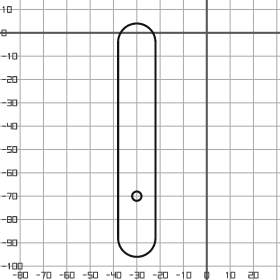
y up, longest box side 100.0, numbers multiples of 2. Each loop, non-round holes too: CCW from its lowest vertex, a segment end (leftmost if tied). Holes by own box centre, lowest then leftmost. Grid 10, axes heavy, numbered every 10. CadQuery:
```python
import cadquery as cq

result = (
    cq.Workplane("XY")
    .moveTo(-38.0, -88.0)
    .threePointArc((-30.0, -96.0), (-22.0, -88.0))
    .lineTo(-22.0, -4.0)
    .threePointArc((-30.0, 4.0), (-38.0, -4.0))
    .close()
    .moveTo(-30.0, -70.0)
    .circle(2.0)
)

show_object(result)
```